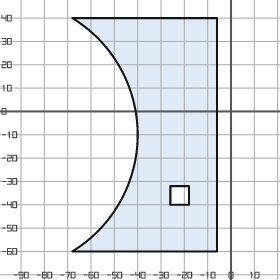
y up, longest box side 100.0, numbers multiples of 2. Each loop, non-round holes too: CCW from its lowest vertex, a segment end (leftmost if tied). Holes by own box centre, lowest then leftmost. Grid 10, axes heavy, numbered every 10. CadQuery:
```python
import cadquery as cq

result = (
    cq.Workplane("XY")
    .moveTo(-68.0, -60.0)
    .lineTo(-6.0, -60.0)
    .lineTo(-6.0, 40.0)
    .lineTo(-68.0, 40.0)
    .threePointArc((-40.0, -10.0), (-68.0, -60.0))
    .close()
    .moveTo(-26.0, -40.0)
    .lineTo(-18.0, -40.0)
    .lineTo(-18.0, -32.0)
    .lineTo(-26.0, -32.0)
    .close()
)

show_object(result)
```